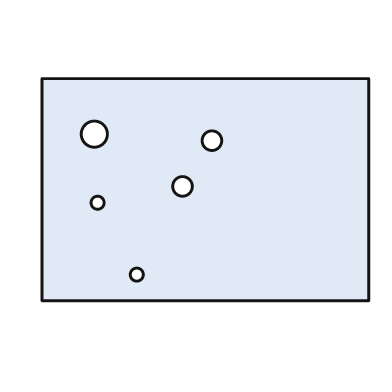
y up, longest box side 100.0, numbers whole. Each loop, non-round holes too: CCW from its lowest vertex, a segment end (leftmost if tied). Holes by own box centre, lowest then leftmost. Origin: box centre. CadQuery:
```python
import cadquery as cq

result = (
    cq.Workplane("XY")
    .moveTo(-50.0, -34.0)
    .lineTo(50.0, -34.0)
    .lineTo(50.0, 34.0)
    .lineTo(-50.0, 34.0)
    .close()
    .moveTo(-21.0, -26.0)
    .circle(2.0)
    .moveTo(-33.0, -4.0)
    .circle(2.0)
    .moveTo(-7.0, 1.0)
    .circle(3.0)
    .moveTo(2.0, 15.0)
    .circle(3.0)
    .moveTo(-34.0, 17.0)
    .circle(4.0)
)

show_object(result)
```